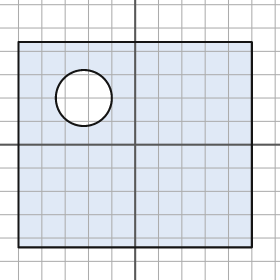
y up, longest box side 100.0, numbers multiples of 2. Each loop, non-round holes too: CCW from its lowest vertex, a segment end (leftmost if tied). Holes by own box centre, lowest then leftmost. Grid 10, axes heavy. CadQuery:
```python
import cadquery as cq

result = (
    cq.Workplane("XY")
    .moveTo(-50.0, -44.0)
    .lineTo(50.0, -44.0)
    .lineTo(50.0, 44.0)
    .lineTo(-50.0, 44.0)
    .close()
    .moveTo(-22.0, 20.0)
    .circle(12.0)
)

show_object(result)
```